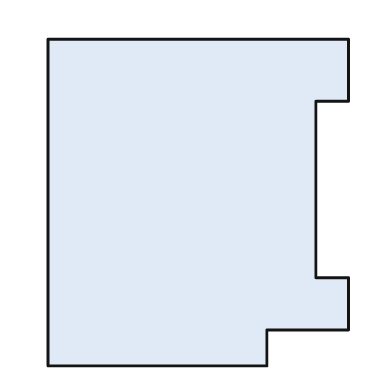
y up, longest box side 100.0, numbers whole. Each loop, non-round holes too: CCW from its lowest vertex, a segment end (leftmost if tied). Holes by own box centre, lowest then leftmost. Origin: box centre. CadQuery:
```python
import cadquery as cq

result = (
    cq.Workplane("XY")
    .moveTo(-46.0, -50.0)
    .lineTo(21.0, -50.0)
    .lineTo(21.0, -39.0)
    .lineTo(46.0, -39.0)
    .lineTo(46.0, -23.0)
    .lineTo(36.0, -23.0)
    .lineTo(36.0, 31.0)
    .lineTo(46.0, 31.0)
    .lineTo(46.0, 50.0)
    .lineTo(-46.0, 50.0)
    .close()
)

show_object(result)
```